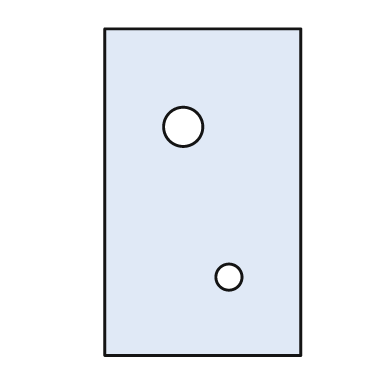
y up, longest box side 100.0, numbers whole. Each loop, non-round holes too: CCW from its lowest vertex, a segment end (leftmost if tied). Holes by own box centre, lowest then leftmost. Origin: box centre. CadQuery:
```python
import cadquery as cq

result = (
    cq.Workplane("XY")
    .moveTo(-30.0, -50.0)
    .lineTo(30.0, -50.0)
    .lineTo(30.0, 50.0)
    .lineTo(-30.0, 50.0)
    .close()
    .moveTo(8.0, -26.0)
    .circle(4.0)
    .moveTo(-6.0, 20.0)
    .circle(6.0)
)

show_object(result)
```